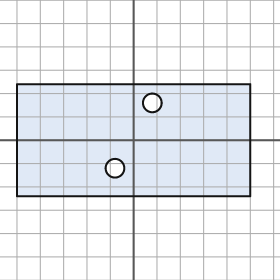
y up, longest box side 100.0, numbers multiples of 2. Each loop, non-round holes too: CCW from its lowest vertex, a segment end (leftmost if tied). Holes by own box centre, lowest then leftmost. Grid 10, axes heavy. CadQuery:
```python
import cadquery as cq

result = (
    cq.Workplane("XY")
    .moveTo(-50.0, -24.0)
    .lineTo(50.0, -24.0)
    .lineTo(50.0, 24.0)
    .lineTo(-50.0, 24.0)
    .close()
    .moveTo(-8.0, -12.0)
    .circle(4.0)
    .moveTo(8.0, 16.0)
    .circle(4.0)
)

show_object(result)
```